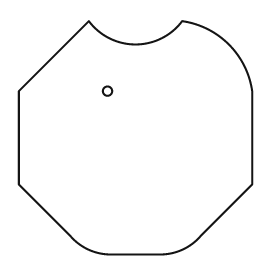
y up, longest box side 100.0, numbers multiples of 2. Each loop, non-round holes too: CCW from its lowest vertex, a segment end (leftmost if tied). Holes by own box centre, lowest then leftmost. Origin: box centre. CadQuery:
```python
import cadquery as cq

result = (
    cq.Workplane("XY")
    .moveTo(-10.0, -50.0)
    .lineTo(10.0, -50.0)
    .threePointArc((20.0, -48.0), (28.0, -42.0))
    .lineTo(50.0, -20.0)
    .lineTo(50.0, 20.0)
    .threePointArc((40.0, 40.0), (20.0, 50.0))
    .threePointArc((0.0, 40.0), (-20.0, 50.0))
    .lineTo(-50.0, 20.0)
    .lineTo(-50.0, -20.0)
    .lineTo(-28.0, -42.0)
    .threePointArc((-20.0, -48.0), (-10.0, -50.0))
    .close()
    .moveTo(-12.0, 20.0)
    .circle(2.0)
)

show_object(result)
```